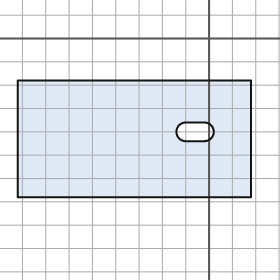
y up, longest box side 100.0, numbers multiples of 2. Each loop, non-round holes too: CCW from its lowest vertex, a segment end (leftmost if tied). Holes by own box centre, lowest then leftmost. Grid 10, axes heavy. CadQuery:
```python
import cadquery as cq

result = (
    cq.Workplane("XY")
    .moveTo(-82.0, -68.0)
    .lineTo(18.0, -68.0)
    .lineTo(18.0, -18.0)
    .lineTo(-82.0, -18.0)
    .close()
    .moveTo(-10.0, -44.0)
    .lineTo(-2.0, -44.0)
    .threePointArc((2.0, -40.0), (-2.0, -36.0))
    .lineTo(-10.0, -36.0)
    .threePointArc((-14.0, -40.0), (-10.0, -44.0))
    .close()
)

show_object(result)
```